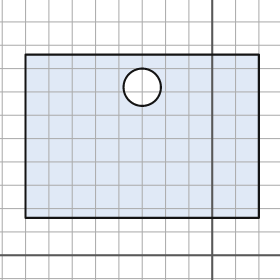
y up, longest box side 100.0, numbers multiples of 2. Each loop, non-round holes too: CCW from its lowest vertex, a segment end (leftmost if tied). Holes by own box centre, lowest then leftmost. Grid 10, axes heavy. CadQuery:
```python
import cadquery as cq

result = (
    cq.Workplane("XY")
    .moveTo(-80.0, 16.0)
    .lineTo(20.0, 16.0)
    .lineTo(20.0, 86.0)
    .lineTo(-80.0, 86.0)
    .close()
    .moveTo(-30.0, 72.0)
    .circle(8.0)
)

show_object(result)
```